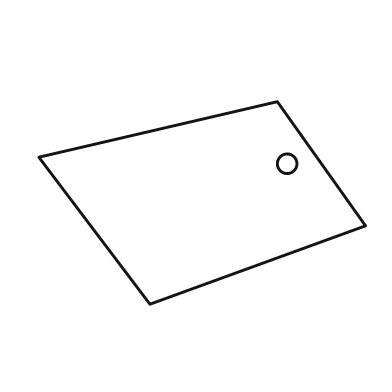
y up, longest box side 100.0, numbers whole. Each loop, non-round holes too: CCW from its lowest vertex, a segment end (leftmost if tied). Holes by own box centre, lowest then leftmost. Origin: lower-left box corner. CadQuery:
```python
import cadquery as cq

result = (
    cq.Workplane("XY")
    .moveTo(34.0, 0.0)
    .lineTo(100.0, 24.0)
    .lineTo(73.0, 62.0)
    .lineTo(0.0, 45.0)
    .close()
    .moveTo(76.0, 43.0)
    .circle(3.0)
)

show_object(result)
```